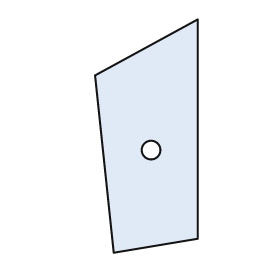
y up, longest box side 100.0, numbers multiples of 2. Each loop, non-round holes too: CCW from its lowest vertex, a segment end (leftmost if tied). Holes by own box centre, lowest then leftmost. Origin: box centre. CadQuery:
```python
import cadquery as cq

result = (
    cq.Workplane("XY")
    .moveTo(-14.0, -50.0)
    .lineTo(22.0, -44.0)
    .lineTo(22.0, 50.0)
    .lineTo(-22.0, 26.0)
    .close()
    .moveTo(2.0, -6.0)
    .circle(4.0)
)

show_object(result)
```